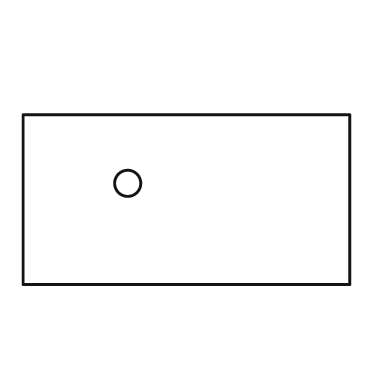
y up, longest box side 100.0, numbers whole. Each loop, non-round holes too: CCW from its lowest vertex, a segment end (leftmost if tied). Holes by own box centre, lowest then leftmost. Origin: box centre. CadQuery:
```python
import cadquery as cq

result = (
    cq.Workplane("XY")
    .moveTo(-50.0, -26.0)
    .lineTo(50.0, -26.0)
    .lineTo(50.0, 26.0)
    .lineTo(-50.0, 26.0)
    .close()
    .moveTo(-18.0, 5.0)
    .circle(4.0)
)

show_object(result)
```